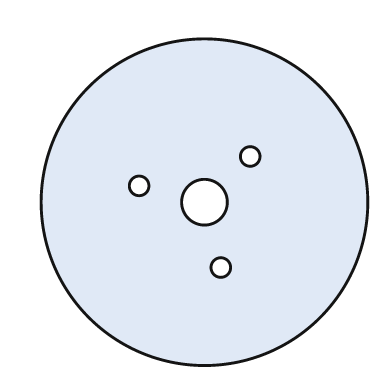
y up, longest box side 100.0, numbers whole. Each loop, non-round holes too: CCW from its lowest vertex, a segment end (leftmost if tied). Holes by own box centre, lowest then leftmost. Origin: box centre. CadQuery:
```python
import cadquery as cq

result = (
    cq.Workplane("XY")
    .moveTo(0.0, 0.0)
    .circle(50.0)
    .moveTo(5.0, -20.0)
    .circle(3.0)
    .moveTo(0.0, 0.0)
    .circle(7.0)
    .moveTo(-20.0, 5.0)
    .circle(3.0)
    .moveTo(14.0, 14.0)
    .circle(3.0)
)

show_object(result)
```